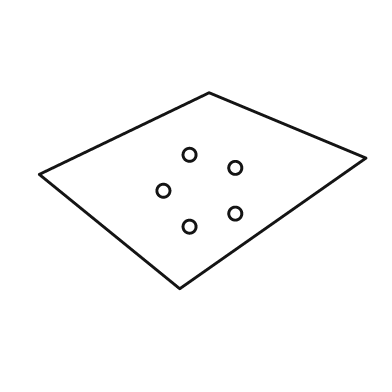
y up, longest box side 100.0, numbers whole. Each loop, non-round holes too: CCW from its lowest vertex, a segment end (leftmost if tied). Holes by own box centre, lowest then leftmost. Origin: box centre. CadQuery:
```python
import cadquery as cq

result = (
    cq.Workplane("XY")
    .moveTo(-7.0, -30.0)
    .lineTo(50.0, 10.0)
    .lineTo(2.0, 30.0)
    .lineTo(-50.0, 5.0)
    .close()
    .moveTo(-4.0, -11.0)
    .circle(2.0)
    .moveTo(10.0, -7.0)
    .circle(2.0)
    .moveTo(-12.0, 0.0)
    .circle(2.0)
    .moveTo(10.0, 7.0)
    .circle(2.0)
    .moveTo(-4.0, 11.0)
    .circle(2.0)
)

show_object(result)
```